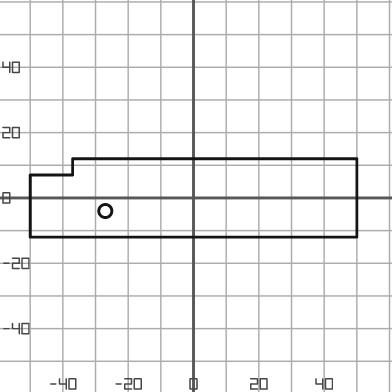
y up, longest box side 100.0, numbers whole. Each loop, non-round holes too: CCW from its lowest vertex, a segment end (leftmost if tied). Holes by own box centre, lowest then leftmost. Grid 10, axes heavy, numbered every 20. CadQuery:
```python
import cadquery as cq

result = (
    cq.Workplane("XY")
    .moveTo(-50.0, -12.0)
    .lineTo(50.0, -12.0)
    .lineTo(50.0, 12.0)
    .lineTo(-37.0, 12.0)
    .lineTo(-37.0, 7.0)
    .lineTo(-50.0, 7.0)
    .close()
    .moveTo(-27.0, -4.0)
    .circle(2.0)
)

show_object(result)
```